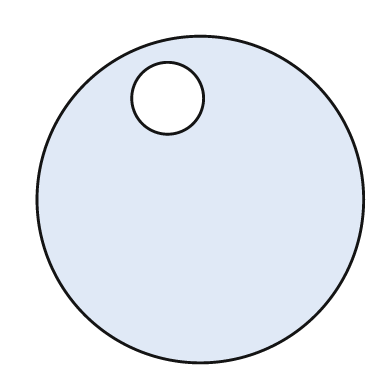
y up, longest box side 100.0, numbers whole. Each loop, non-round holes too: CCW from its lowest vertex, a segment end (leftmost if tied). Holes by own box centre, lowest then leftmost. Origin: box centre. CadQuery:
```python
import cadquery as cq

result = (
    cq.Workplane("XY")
    .moveTo(0.0, 0.0)
    .circle(50.0)
    .moveTo(-10.0, 31.0)
    .circle(11.0)
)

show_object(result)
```